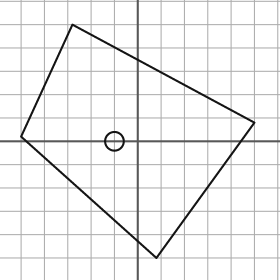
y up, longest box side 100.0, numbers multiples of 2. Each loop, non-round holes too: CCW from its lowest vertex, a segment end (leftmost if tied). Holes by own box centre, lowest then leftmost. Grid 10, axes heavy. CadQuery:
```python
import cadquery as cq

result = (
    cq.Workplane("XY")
    .moveTo(8.0, -50.0)
    .lineTo(50.0, 8.0)
    .lineTo(-28.0, 50.0)
    .lineTo(-50.0, 2.0)
    .close()
    .moveTo(-10.0, 0.0)
    .circle(4.0)
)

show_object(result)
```